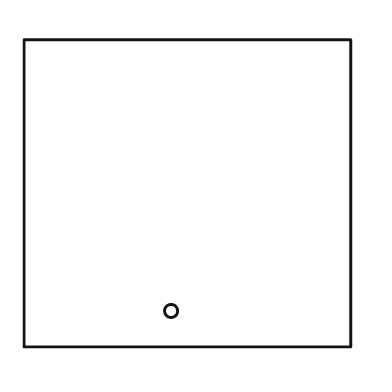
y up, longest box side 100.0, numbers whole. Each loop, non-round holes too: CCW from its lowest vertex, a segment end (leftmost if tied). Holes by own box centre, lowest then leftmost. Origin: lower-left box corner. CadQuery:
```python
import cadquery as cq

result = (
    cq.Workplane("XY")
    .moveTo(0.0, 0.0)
    .lineTo(100.0, 0.0)
    .lineTo(100.0, 94.0)
    .lineTo(0.0, 94.0)
    .close()
    .moveTo(45.0, 11.0)
    .circle(2.0)
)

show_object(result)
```